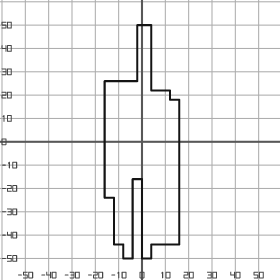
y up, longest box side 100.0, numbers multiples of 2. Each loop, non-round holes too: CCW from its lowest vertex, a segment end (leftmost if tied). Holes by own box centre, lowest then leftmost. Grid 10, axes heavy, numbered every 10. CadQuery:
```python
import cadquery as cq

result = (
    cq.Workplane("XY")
    .moveTo(-8.0, -50.0)
    .lineTo(-4.0, -50.0)
    .lineTo(-4.0, -16.0)
    .lineTo(0.0, -16.0)
    .lineTo(0.0, -50.0)
    .lineTo(4.0, -50.0)
    .lineTo(4.0, -44.0)
    .lineTo(16.0, -44.0)
    .lineTo(16.0, 18.0)
    .lineTo(12.0, 18.0)
    .lineTo(12.0, 22.0)
    .lineTo(4.0, 22.0)
    .lineTo(4.0, 50.0)
    .lineTo(-2.0, 50.0)
    .lineTo(-2.0, 26.0)
    .lineTo(-16.0, 26.0)
    .lineTo(-16.0, -24.0)
    .lineTo(-12.0, -24.0)
    .lineTo(-12.0, -44.0)
    .lineTo(-8.0, -44.0)
    .close()
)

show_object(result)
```